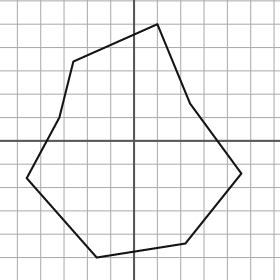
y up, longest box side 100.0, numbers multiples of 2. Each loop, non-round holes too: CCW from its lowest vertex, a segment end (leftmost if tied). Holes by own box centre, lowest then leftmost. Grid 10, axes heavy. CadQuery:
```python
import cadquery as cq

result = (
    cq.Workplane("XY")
    .moveTo(-16.0, -50.0)
    .lineTo(22.0, -44.0)
    .lineTo(46.0, -14.0)
    .lineTo(24.0, 16.0)
    .lineTo(10.0, 50.0)
    .lineTo(-26.0, 34.0)
    .lineTo(-32.0, 10.0)
    .lineTo(-46.0, -16.0)
    .close()
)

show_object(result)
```